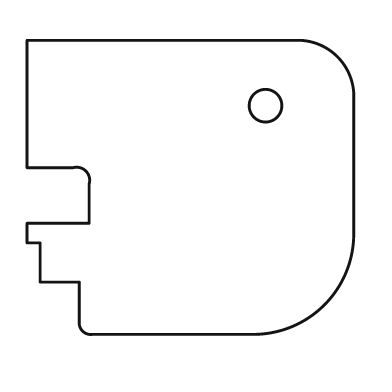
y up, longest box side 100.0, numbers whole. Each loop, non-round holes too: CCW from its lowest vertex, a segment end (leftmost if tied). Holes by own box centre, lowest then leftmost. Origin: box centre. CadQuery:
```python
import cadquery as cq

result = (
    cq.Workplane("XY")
    .moveTo(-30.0, -45.0)
    .lineTo(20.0, -45.0)
    .threePointArc((41.0, -36.0), (50.0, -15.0))
    .lineTo(50.0, 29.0)
    .threePointArc((45.0, 40.0), (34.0, 45.0))
    .lineTo(-50.0, 45.0)
    .lineTo(-50.0, 6.0)
    .lineTo(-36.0, 6.0)
    .threePointArc((-32.0, 5.0), (-31.0, 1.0))
    .lineTo(-31.0, -11.0)
    .lineTo(-50.0, -11.0)
    .lineTo(-50.0, -17.0)
    .lineTo(-46.0, -17.0)
    .lineTo(-46.0, -29.0)
    .lineTo(-34.0, -29.0)
    .lineTo(-34.0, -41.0)
    .threePointArc((-33.0, -44.0), (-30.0, -45.0))
    .close()
    .moveTo(23.0, 25.0)
    .circle(5.0)
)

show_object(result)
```